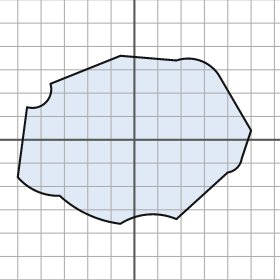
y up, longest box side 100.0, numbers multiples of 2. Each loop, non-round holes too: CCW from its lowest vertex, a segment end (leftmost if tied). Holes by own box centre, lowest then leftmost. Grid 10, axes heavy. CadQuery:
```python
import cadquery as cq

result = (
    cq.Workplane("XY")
    .moveTo(-6.0, -36.0)
    .threePointArc((6.0, -32.0), (18.0, -34.0))
    .lineTo(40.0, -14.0)
    .threePointArc((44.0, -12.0), (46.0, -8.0))
    .lineTo(50.0, 4.0)
    .lineTo(36.0, 28.0)
    .threePointArc((28.0, 34.0), (18.0, 34.0))
    .lineTo(-6.0, 36.0)
    .lineTo(-36.0, 24.0)
    .threePointArc((-38.0, 16.0), (-46.0, 14.0))
    .lineTo(-50.0, -16.0)
    .threePointArc((-42.0, -22.0), (-32.0, -24.0))
    .threePointArc((-20.0, -32.0), (-6.0, -36.0))
    .close()
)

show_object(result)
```